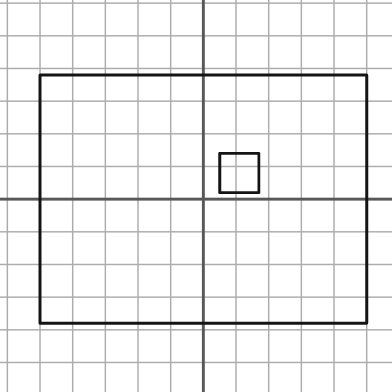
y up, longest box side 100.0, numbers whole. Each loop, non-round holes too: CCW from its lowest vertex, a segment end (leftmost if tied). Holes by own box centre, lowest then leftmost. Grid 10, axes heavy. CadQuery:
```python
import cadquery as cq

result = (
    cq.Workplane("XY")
    .moveTo(-50.0, -38.0)
    .lineTo(50.0, -38.0)
    .lineTo(50.0, 38.0)
    .lineTo(-50.0, 38.0)
    .close()
    .moveTo(5.0, 2.0)
    .lineTo(17.0, 2.0)
    .lineTo(17.0, 14.0)
    .lineTo(5.0, 14.0)
    .close()
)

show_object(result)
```